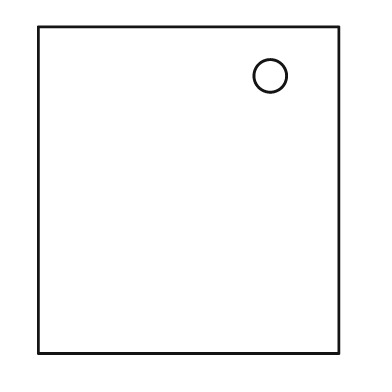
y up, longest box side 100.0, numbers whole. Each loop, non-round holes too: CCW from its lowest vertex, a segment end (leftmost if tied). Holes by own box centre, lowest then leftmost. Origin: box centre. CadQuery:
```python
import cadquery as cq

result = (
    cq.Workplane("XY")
    .moveTo(-46.0, -50.0)
    .lineTo(46.0, -50.0)
    .lineTo(46.0, 50.0)
    .lineTo(-46.0, 50.0)
    .close()
    .moveTo(25.0, 35.0)
    .circle(5.0)
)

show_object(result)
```